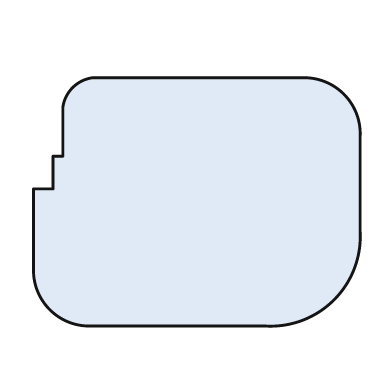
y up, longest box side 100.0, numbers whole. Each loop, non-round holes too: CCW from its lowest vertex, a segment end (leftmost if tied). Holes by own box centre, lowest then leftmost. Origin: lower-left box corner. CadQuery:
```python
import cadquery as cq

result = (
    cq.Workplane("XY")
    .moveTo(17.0, 0.0)
    .lineTo(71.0, 0.0)
    .threePointArc((92.0, 8.0), (100.0, 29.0))
    .lineTo(100.0, 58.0)
    .threePointArc((95.0, 71.0), (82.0, 76.0))
    .lineTo(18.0, 76.0)
    .threePointArc((12.0, 73.0), (9.0, 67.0))
    .lineTo(9.0, 52.0)
    .lineTo(6.0, 52.0)
    .lineTo(6.0, 42.0)
    .lineTo(0.0, 42.0)
    .lineTo(0.0, 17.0)
    .threePointArc((5.0, 5.0), (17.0, 0.0))
    .close()
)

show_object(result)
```